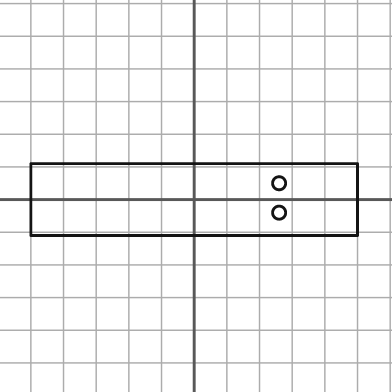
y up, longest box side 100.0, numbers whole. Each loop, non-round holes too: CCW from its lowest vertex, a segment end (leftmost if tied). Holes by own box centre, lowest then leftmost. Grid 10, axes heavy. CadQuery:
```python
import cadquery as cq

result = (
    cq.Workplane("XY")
    .moveTo(-50.0, -11.0)
    .lineTo(50.0, -11.0)
    .lineTo(50.0, 11.0)
    .lineTo(-50.0, 11.0)
    .close()
    .moveTo(26.0, -4.0)
    .circle(2.0)
    .moveTo(26.0, 5.0)
    .circle(2.0)
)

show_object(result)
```